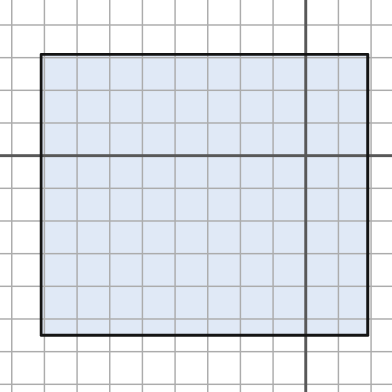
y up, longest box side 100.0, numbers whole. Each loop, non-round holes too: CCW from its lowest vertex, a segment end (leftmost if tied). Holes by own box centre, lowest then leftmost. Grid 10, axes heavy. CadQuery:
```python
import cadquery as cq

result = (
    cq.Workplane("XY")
    .moveTo(-81.0, -55.0)
    .lineTo(19.0, -55.0)
    .lineTo(19.0, 31.0)
    .lineTo(-81.0, 31.0)
    .close()
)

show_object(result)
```